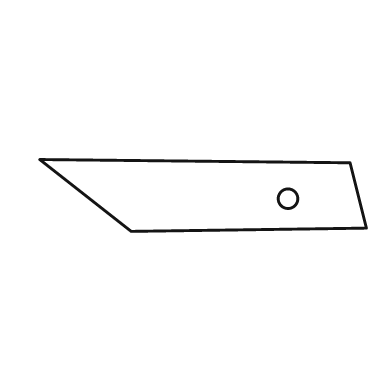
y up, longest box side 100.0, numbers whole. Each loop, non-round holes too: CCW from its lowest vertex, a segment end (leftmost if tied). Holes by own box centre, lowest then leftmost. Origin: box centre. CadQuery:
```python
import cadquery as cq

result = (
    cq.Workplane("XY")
    .moveTo(-22.0, -11.0)
    .lineTo(50.0, -10.0)
    .lineTo(45.0, 10.0)
    .lineTo(-50.0, 11.0)
    .close()
    .moveTo(26.0, -1.0)
    .circle(3.0)
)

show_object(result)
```